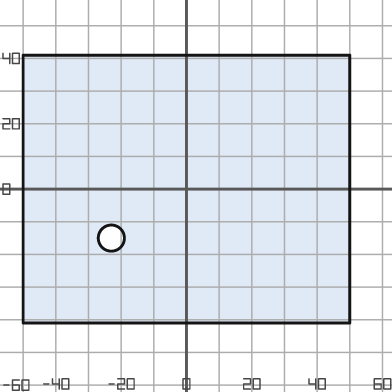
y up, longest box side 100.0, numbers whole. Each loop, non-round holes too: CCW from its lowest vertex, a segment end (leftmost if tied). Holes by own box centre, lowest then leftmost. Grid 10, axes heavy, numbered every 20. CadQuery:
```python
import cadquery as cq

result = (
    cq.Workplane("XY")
    .moveTo(-50.0, -41.0)
    .lineTo(50.0, -41.0)
    .lineTo(50.0, 41.0)
    .lineTo(-50.0, 41.0)
    .close()
    .moveTo(-23.0, -15.0)
    .circle(4.0)
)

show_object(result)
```